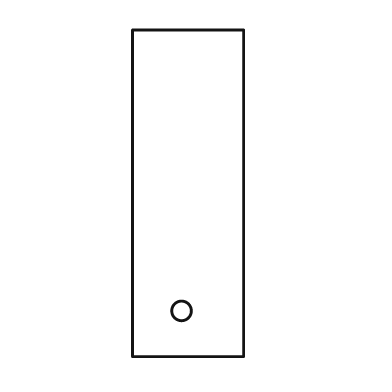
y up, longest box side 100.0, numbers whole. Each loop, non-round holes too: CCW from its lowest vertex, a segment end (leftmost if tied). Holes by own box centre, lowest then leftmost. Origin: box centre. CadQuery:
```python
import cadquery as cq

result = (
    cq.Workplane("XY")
    .moveTo(-17.0, -50.0)
    .lineTo(17.0, -50.0)
    .lineTo(17.0, 50.0)
    .lineTo(-17.0, 50.0)
    .close()
    .moveTo(-2.0, -36.0)
    .circle(3.0)
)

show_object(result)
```